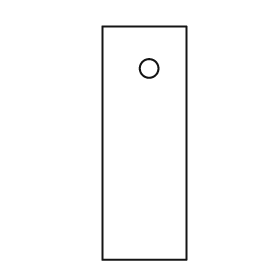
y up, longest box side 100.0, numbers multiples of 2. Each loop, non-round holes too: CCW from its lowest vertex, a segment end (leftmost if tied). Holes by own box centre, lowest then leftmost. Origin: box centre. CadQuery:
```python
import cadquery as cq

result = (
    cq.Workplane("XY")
    .moveTo(-18.0, -50.0)
    .lineTo(18.0, -50.0)
    .lineTo(18.0, 50.0)
    .lineTo(-18.0, 50.0)
    .close()
    .moveTo(2.0, 32.0)
    .circle(4.0)
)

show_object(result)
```